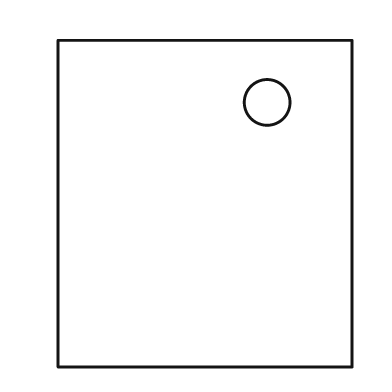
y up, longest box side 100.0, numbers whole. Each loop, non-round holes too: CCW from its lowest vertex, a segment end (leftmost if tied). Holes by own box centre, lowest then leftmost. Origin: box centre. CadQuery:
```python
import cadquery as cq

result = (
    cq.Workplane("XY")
    .moveTo(-45.0, -50.0)
    .lineTo(45.0, -50.0)
    .lineTo(45.0, 50.0)
    .lineTo(-45.0, 50.0)
    .close()
    .moveTo(19.0, 31.0)
    .circle(7.0)
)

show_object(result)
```